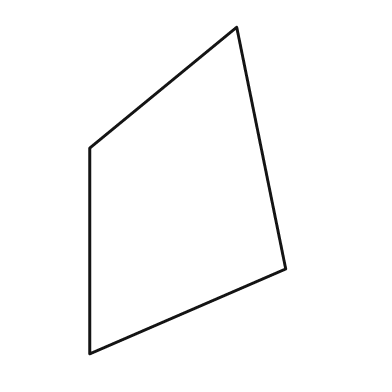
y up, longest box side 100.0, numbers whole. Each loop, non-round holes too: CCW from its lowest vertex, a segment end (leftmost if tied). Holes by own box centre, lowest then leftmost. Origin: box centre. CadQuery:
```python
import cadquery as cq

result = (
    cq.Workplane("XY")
    .moveTo(-30.0, -50.0)
    .lineTo(30.0, -24.0)
    .lineTo(15.0, 50.0)
    .lineTo(-30.0, 13.0)
    .close()
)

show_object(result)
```